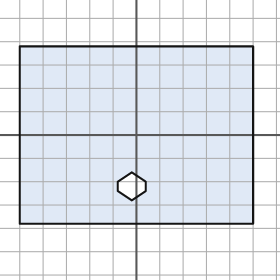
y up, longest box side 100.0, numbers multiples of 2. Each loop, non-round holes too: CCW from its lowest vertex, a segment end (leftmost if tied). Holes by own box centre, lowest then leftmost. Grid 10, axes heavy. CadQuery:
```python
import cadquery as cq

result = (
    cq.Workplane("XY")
    .moveTo(-50.0, -38.0)
    .lineTo(50.0, -38.0)
    .lineTo(50.0, 38.0)
    .lineTo(-50.0, 38.0)
    .close()
    .moveTo(-2.0, -28.0)
    .lineTo(4.0, -24.0)
    .lineTo(4.0, -20.0)
    .lineTo(-2.0, -16.0)
    .lineTo(-8.0, -20.0)
    .lineTo(-8.0, -24.0)
    .close()
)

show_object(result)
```